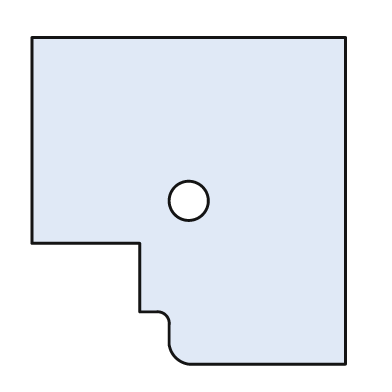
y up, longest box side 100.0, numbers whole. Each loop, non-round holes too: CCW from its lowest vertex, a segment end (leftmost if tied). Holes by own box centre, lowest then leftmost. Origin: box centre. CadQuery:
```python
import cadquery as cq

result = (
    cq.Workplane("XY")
    .moveTo(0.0, -50.0)
    .lineTo(48.0, -50.0)
    .lineTo(48.0, 50.0)
    .lineTo(-48.0, 50.0)
    .lineTo(-48.0, -13.0)
    .lineTo(-15.0, -13.0)
    .lineTo(-15.0, -34.0)
    .lineTo(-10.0, -34.0)
    .threePointArc((-7.0, -35.0), (-6.0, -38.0))
    .lineTo(-6.0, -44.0)
    .threePointArc((-4.0, -48.0), (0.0, -50.0))
    .close()
    .moveTo(0.0, 0.0)
    .circle(6.0)
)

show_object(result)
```